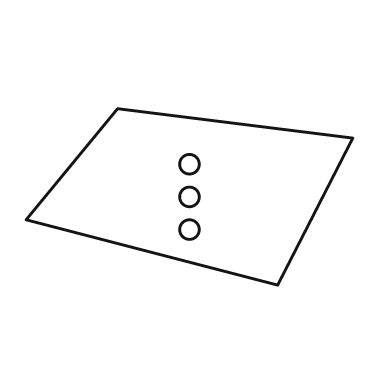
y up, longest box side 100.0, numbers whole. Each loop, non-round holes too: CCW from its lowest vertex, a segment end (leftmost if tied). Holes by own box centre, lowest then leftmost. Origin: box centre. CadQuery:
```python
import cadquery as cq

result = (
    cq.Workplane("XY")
    .moveTo(27.0, -27.0)
    .lineTo(50.0, 18.0)
    .lineTo(-22.0, 27.0)
    .lineTo(-50.0, -7.0)
    .close()
    .moveTo(0.0, -10.0)
    .circle(3.0)
    .moveTo(0.0, 0.0)
    .circle(3.0)
    .moveTo(0.0, 10.0)
    .circle(3.0)
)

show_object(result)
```